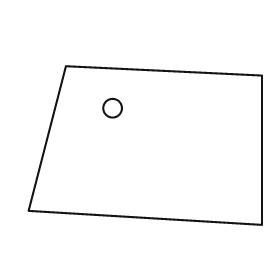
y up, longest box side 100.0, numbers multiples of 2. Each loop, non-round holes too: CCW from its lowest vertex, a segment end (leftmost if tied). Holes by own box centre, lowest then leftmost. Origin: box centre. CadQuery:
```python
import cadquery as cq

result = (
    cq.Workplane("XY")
    .moveTo(50.0, -34.0)
    .lineTo(50.0, 30.0)
    .lineTo(-34.0, 34.0)
    .lineTo(-50.0, -28.0)
    .close()
    .moveTo(-14.0, 16.0)
    .circle(4.0)
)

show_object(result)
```